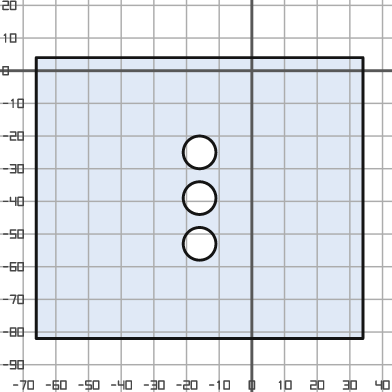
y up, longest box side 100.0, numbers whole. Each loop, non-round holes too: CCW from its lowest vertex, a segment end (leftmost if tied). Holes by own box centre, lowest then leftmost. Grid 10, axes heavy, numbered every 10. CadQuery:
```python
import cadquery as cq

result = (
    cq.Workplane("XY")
    .moveTo(-66.0, -82.0)
    .lineTo(34.0, -82.0)
    .lineTo(34.0, 4.0)
    .lineTo(-66.0, 4.0)
    .close()
    .moveTo(-16.0, -53.0)
    .circle(5.0)
    .moveTo(-16.0, -39.0)
    .circle(5.0)
    .moveTo(-16.0, -25.0)
    .circle(5.0)
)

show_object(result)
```